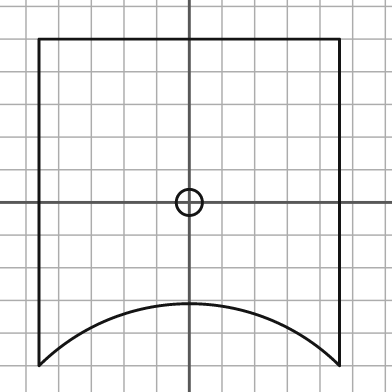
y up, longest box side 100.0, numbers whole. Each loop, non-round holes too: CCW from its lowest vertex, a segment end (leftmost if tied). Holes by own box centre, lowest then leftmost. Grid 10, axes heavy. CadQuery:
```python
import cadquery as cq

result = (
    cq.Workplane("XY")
    .moveTo(-46.0, -50.0)
    .threePointArc((0.0, -31.0), (46.0, -50.0))
    .lineTo(46.0, 50.0)
    .lineTo(-46.0, 50.0)
    .close()
    .moveTo(0.0, 0.0)
    .circle(4.0)
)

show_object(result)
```